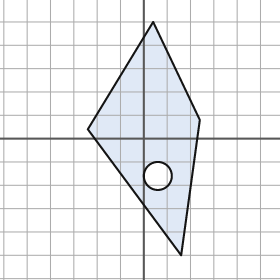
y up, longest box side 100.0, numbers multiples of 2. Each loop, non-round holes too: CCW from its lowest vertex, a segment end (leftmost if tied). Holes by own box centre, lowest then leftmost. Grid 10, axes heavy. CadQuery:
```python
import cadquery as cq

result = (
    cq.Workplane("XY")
    .moveTo(16.0, -50.0)
    .lineTo(24.0, 8.0)
    .lineTo(4.0, 50.0)
    .lineTo(-24.0, 4.0)
    .close()
    .moveTo(6.0, -16.0)
    .circle(6.0)
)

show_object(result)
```